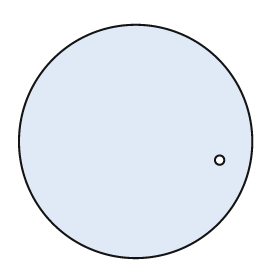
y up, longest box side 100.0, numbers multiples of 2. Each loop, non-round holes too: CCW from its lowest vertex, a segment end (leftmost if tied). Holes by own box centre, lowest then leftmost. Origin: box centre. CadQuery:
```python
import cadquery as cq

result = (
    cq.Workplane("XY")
    .moveTo(0.0, 0.0)
    .circle(50.0)
    .moveTo(36.0, -8.0)
    .circle(2.0)
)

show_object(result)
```